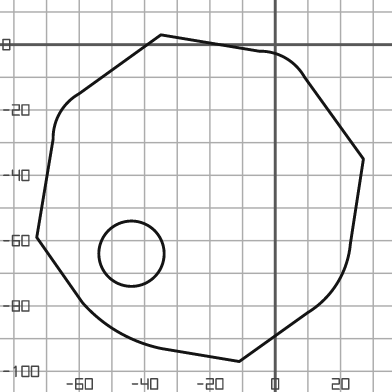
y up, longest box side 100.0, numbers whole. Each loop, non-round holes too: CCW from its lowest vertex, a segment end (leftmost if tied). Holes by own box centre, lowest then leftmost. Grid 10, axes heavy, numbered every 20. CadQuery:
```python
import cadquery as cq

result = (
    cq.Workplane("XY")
    .moveTo(-11.0, -97.0)
    .lineTo(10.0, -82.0)
    .threePointArc((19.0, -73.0), (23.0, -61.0))
    .lineTo(27.0, -35.0)
    .lineTo(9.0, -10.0)
    .threePointArc((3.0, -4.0), (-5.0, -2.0))
    .lineTo(-35.0, 3.0)
    .lineTo(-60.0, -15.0)
    .threePointArc((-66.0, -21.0), (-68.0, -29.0))
    .lineTo(-73.0, -59.0)
    .lineTo(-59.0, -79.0)
    .threePointArc((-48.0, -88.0), (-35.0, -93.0))
    .close()
    .moveTo(-44.0, -64.0)
    .circle(10.0)
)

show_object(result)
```